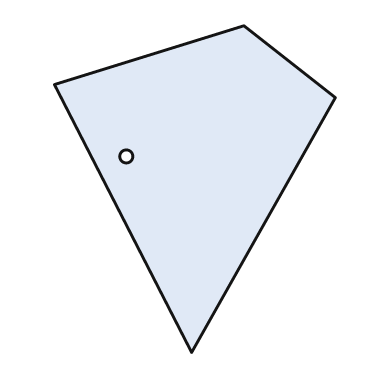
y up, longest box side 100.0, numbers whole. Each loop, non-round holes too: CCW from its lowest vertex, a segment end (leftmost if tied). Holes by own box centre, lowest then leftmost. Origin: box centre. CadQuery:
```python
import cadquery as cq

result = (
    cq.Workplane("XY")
    .moveTo(-1.0, -50.0)
    .lineTo(43.0, 28.0)
    .lineTo(15.0, 50.0)
    .lineTo(-43.0, 32.0)
    .close()
    .moveTo(-21.0, 10.0)
    .circle(2.0)
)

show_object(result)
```